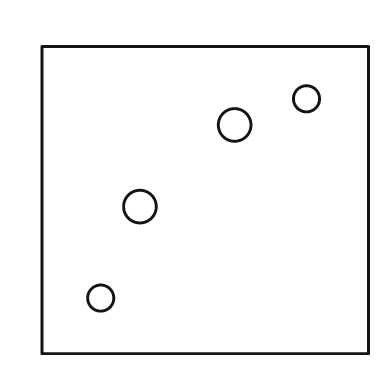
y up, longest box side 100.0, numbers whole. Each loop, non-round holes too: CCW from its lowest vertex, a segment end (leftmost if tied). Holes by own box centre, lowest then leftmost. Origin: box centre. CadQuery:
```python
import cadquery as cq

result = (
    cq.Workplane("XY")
    .moveTo(-50.0, -47.0)
    .lineTo(50.0, -47.0)
    .lineTo(50.0, 47.0)
    .lineTo(-50.0, 47.0)
    .close()
    .moveTo(-32.0, -30.0)
    .circle(4.0)
    .moveTo(-20.0, -2.0)
    .circle(5.0)
    .moveTo(9.0, 23.0)
    .circle(5.0)
    .moveTo(31.0, 31.0)
    .circle(4.0)
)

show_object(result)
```